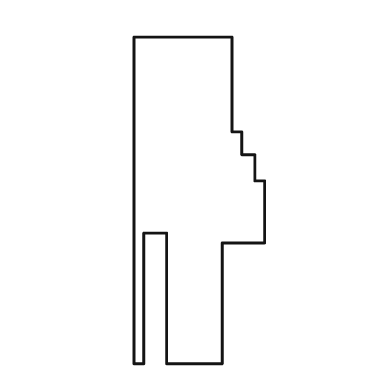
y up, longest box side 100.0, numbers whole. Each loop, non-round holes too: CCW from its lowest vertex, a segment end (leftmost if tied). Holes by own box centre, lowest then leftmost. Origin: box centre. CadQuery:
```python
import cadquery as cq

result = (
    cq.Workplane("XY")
    .moveTo(-20.0, -50.0)
    .lineTo(-17.0, -50.0)
    .lineTo(-17.0, -10.0)
    .lineTo(-10.0, -10.0)
    .lineTo(-10.0, -50.0)
    .lineTo(7.0, -50.0)
    .lineTo(7.0, -13.0)
    .lineTo(20.0, -13.0)
    .lineTo(20.0, 6.0)
    .lineTo(17.0, 6.0)
    .lineTo(17.0, 14.0)
    .lineTo(13.0, 14.0)
    .lineTo(13.0, 21.0)
    .lineTo(10.0, 21.0)
    .lineTo(10.0, 50.0)
    .lineTo(-20.0, 50.0)
    .close()
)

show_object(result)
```